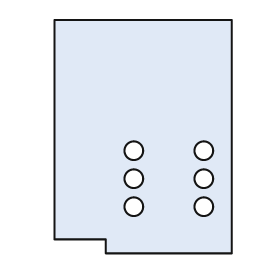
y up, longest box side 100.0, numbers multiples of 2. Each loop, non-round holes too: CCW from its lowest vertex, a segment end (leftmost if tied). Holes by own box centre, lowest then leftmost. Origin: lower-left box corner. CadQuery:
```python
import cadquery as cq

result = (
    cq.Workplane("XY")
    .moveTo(22.0, 0.0)
    .lineTo(76.0, 0.0)
    .lineTo(76.0, 100.0)
    .lineTo(0.0, 100.0)
    .lineTo(0.0, 6.0)
    .lineTo(22.0, 6.0)
    .close()
    .moveTo(34.0, 20.0)
    .circle(4.0)
    .moveTo(64.0, 20.0)
    .circle(4.0)
    .moveTo(34.0, 32.0)
    .circle(4.0)
    .moveTo(64.0, 32.0)
    .circle(4.0)
    .moveTo(34.0, 44.0)
    .circle(4.0)
    .moveTo(64.0, 44.0)
    .circle(4.0)
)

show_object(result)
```